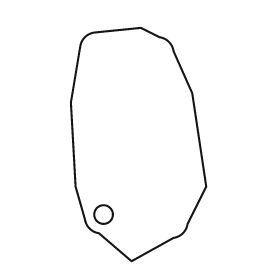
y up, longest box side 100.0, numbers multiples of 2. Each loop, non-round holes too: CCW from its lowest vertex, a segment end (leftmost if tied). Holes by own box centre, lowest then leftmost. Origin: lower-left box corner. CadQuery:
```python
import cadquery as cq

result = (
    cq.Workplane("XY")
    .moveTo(26.0, 0.0)
    .lineTo(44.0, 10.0)
    .threePointArc((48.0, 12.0), (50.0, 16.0))
    .lineTo(58.0, 32.0)
    .lineTo(52.0, 72.0)
    .lineTo(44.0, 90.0)
    .threePointArc((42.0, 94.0), (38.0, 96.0))
    .lineTo(30.0, 100.0)
    .lineTo(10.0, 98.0)
    .threePointArc((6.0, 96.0), (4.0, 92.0))
    .lineTo(0.0, 68.0)
    .lineTo(2.0, 32.0)
    .lineTo(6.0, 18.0)
    .threePointArc((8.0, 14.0), (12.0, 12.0))
    .close()
    .moveTo(14.0, 20.0)
    .circle(4.0)
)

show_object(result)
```